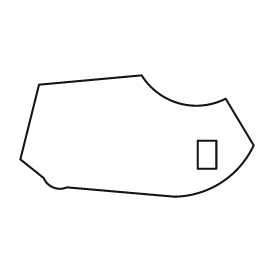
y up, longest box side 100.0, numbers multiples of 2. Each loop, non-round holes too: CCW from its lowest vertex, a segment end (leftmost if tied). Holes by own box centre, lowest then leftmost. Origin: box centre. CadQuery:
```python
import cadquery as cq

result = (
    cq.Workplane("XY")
    .moveTo(16.0, -26.0)
    .threePointArc((36.0, -20.0), (50.0, -4.0))
    .lineTo(38.0, 16.0)
    .threePointArc((18.0, 14.0), (2.0, 26.0))
    .lineTo(-42.0, 22.0)
    .lineTo(-50.0, -10.0)
    .lineTo(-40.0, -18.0)
    .threePointArc((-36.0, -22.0), (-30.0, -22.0))
    .close()
    .moveTo(26.0, -14.0)
    .lineTo(34.0, -14.0)
    .lineTo(34.0, -2.0)
    .lineTo(26.0, -2.0)
    .close()
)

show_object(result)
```